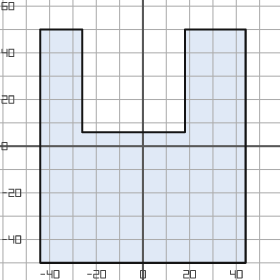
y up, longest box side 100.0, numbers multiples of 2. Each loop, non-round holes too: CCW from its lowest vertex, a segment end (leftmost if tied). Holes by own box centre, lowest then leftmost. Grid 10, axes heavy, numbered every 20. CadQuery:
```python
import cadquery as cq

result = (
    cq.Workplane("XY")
    .moveTo(-44.0, -50.0)
    .lineTo(44.0, -50.0)
    .lineTo(44.0, 50.0)
    .lineTo(18.0, 50.0)
    .lineTo(18.0, 6.0)
    .lineTo(-26.0, 6.0)
    .lineTo(-26.0, 50.0)
    .lineTo(-44.0, 50.0)
    .close()
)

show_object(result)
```